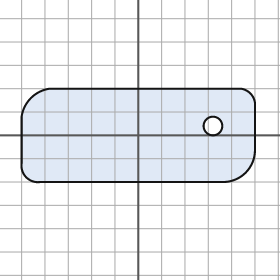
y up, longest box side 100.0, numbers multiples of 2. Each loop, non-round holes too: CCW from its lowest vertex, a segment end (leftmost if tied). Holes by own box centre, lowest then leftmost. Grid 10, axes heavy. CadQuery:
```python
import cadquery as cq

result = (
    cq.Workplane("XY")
    .moveTo(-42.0, -20.0)
    .lineTo(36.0, -20.0)
    .threePointArc((46.0, -16.0), (50.0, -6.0))
    .lineTo(50.0, 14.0)
    .threePointArc((48.0, 18.0), (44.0, 20.0))
    .lineTo(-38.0, 20.0)
    .threePointArc((-46.0, 16.0), (-50.0, 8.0))
    .lineTo(-50.0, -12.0)
    .threePointArc((-48.0, -18.0), (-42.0, -20.0))
    .close()
    .moveTo(32.0, 4.0)
    .circle(4.0)
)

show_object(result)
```